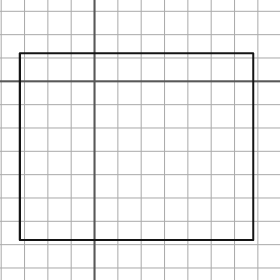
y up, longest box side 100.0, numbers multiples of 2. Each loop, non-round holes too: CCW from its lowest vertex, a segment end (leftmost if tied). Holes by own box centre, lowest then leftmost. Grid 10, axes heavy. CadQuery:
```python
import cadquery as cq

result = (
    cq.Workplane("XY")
    .moveTo(-32.0, -68.0)
    .lineTo(68.0, -68.0)
    .lineTo(68.0, 12.0)
    .lineTo(-32.0, 12.0)
    .close()
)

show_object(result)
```